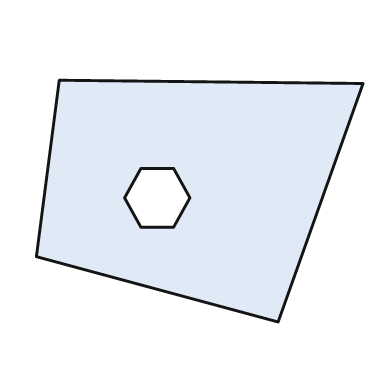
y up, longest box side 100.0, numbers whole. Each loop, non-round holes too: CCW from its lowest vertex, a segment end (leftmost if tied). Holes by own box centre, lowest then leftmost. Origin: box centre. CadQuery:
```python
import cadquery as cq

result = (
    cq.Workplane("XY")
    .moveTo(24.0, -37.0)
    .lineTo(50.0, 36.0)
    .lineTo(-43.0, 37.0)
    .lineTo(-50.0, -17.0)
    .close()
    .moveTo(-18.0, -8.0)
    .lineTo(-8.0, -8.0)
    .lineTo(-3.0, 1.0)
    .lineTo(-8.0, 10.0)
    .lineTo(-18.0, 10.0)
    .lineTo(-23.0, 1.0)
    .close()
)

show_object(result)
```